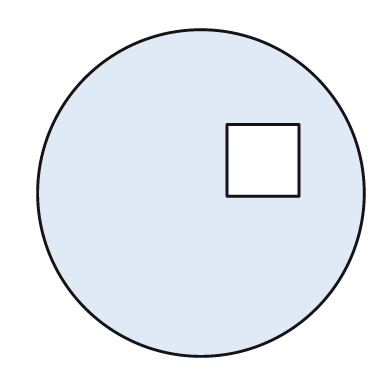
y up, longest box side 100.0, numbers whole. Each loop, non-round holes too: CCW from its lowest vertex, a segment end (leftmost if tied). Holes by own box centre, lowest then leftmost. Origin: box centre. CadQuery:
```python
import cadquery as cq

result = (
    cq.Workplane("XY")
    .moveTo(0.0, 0.0)
    .circle(50.0)
    .moveTo(8.0, -1.0)
    .lineTo(30.0, -1.0)
    .lineTo(30.0, 21.0)
    .lineTo(8.0, 21.0)
    .close()
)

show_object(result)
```